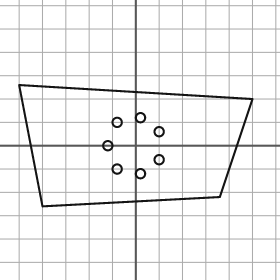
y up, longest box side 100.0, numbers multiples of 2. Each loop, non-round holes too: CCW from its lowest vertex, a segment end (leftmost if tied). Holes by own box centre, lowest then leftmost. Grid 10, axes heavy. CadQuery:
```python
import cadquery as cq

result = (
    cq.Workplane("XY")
    .moveTo(-40.0, -26.0)
    .lineTo(36.0, -22.0)
    .lineTo(50.0, 20.0)
    .lineTo(-50.0, 26.0)
    .close()
    .moveTo(2.0, -12.0)
    .circle(2.0)
    .moveTo(-8.0, -10.0)
    .circle(2.0)
    .moveTo(10.0, -6.0)
    .circle(2.0)
    .moveTo(-12.0, 0.0)
    .circle(2.0)
    .moveTo(10.0, 6.0)
    .circle(2.0)
    .moveTo(-8.0, 10.0)
    .circle(2.0)
    .moveTo(2.0, 12.0)
    .circle(2.0)
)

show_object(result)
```